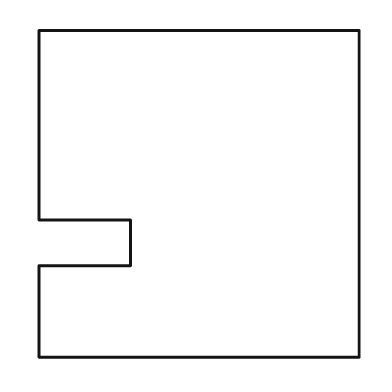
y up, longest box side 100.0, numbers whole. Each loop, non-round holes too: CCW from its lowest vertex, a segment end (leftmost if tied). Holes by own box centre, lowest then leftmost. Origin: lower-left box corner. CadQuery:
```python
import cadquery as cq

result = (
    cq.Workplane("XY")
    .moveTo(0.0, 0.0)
    .lineTo(98.0, 0.0)
    .lineTo(98.0, 100.0)
    .lineTo(0.0, 100.0)
    .lineTo(0.0, 42.0)
    .lineTo(28.0, 42.0)
    .lineTo(28.0, 28.0)
    .lineTo(0.0, 28.0)
    .close()
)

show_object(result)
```